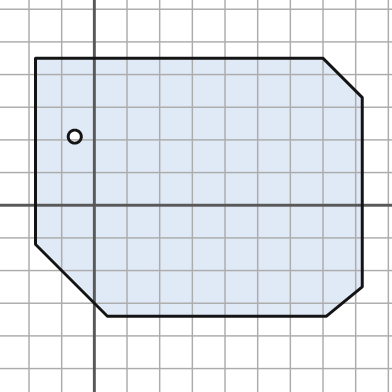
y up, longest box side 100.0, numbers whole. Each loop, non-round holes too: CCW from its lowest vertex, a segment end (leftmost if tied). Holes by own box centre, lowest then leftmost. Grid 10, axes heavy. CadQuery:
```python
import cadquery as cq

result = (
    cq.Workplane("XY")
    .moveTo(4.0, -34.0)
    .lineTo(71.0, -34.0)
    .lineTo(82.0, -25.0)
    .lineTo(82.0, 33.0)
    .lineTo(70.0, 45.0)
    .lineTo(-18.0, 45.0)
    .lineTo(-18.0, -12.0)
    .close()
    .moveTo(-6.0, 21.0)
    .circle(2.0)
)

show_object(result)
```